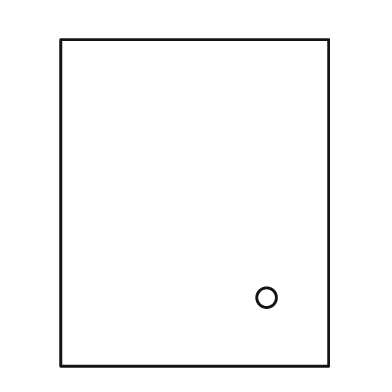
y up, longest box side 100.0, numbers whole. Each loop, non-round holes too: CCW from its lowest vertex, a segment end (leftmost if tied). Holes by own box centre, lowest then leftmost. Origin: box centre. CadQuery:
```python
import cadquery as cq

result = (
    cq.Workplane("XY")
    .moveTo(-41.0, -50.0)
    .lineTo(41.0, -50.0)
    .lineTo(41.0, 50.0)
    .lineTo(-41.0, 50.0)
    .close()
    .moveTo(22.0, -29.0)
    .circle(3.0)
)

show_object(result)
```